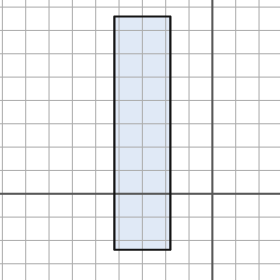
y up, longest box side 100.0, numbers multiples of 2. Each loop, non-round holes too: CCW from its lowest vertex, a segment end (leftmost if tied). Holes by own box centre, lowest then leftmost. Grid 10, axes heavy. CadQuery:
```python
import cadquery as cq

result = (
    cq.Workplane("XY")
    .moveTo(-42.0, -24.0)
    .lineTo(-18.0, -24.0)
    .lineTo(-18.0, 76.0)
    .lineTo(-42.0, 76.0)
    .close()
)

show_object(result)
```